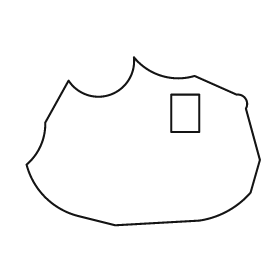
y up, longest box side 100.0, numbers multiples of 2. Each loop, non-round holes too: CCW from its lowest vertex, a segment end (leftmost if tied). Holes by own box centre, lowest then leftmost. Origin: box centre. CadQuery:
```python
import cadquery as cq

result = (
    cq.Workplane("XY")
    .moveTo(-12.0, -36.0)
    .lineTo(24.0, -34.0)
    .threePointArc((36.0, -30.0), (46.0, -22.0))
    .lineTo(50.0, -8.0)
    .lineTo(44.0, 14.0)
    .threePointArc((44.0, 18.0), (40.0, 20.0))
    .lineTo(22.0, 28.0)
    .threePointArc((8.0, 28.0), (-4.0, 36.0))
    .threePointArc((-14.0, 20.0), (-32.0, 26.0))
    .lineTo(-42.0, 8.0)
    .threePointArc((-44.0, -2.0), (-50.0, -10.0))
    .threePointArc((-42.0, -24.0), (-28.0, -32.0))
    .close()
    .moveTo(12.0, 4.0)
    .lineTo(24.0, 4.0)
    .lineTo(24.0, 20.0)
    .lineTo(12.0, 20.0)
    .close()
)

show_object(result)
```